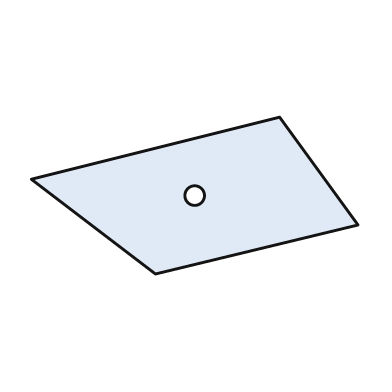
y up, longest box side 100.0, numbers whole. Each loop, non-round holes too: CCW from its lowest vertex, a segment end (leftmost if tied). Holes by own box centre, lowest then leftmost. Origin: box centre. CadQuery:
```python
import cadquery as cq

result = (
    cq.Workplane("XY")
    .moveTo(-12.0, -24.0)
    .lineTo(50.0, -9.0)
    .lineTo(26.0, 24.0)
    .lineTo(-50.0, 5.0)
    .close()
    .moveTo(0.0, 0.0)
    .circle(3.0)
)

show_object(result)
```